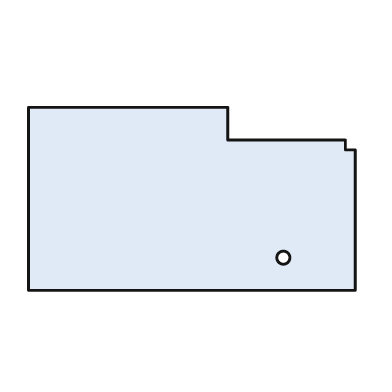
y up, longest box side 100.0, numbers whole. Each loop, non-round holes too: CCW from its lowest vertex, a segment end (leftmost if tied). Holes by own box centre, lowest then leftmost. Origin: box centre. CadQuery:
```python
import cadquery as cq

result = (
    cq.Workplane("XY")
    .moveTo(-50.0, -28.0)
    .lineTo(50.0, -28.0)
    .lineTo(50.0, 15.0)
    .lineTo(47.0, 15.0)
    .lineTo(47.0, 18.0)
    .lineTo(11.0, 18.0)
    .lineTo(11.0, 28.0)
    .lineTo(-50.0, 28.0)
    .close()
    .moveTo(28.0, -18.0)
    .circle(2.0)
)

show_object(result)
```